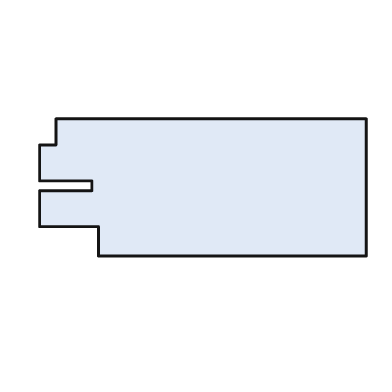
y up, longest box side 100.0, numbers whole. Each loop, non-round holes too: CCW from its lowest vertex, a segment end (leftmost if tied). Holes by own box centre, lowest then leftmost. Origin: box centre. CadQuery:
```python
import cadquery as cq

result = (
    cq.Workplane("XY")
    .moveTo(-32.0, -21.0)
    .lineTo(50.0, -21.0)
    .lineTo(50.0, 21.0)
    .lineTo(-45.0, 21.0)
    .lineTo(-45.0, 13.0)
    .lineTo(-50.0, 13.0)
    .lineTo(-50.0, 2.0)
    .lineTo(-34.0, 2.0)
    .lineTo(-34.0, -1.0)
    .lineTo(-50.0, -1.0)
    .lineTo(-50.0, -12.0)
    .lineTo(-32.0, -12.0)
    .close()
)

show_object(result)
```